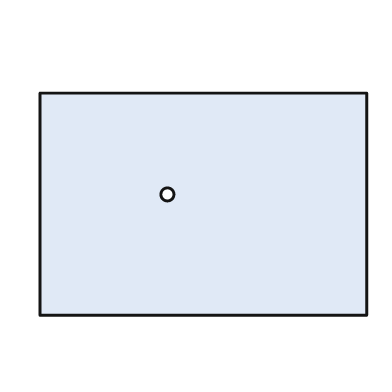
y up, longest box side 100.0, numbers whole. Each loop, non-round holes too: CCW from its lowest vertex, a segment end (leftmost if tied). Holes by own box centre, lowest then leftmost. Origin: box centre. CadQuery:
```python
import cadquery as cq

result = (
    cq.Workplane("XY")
    .moveTo(-50.0, -34.0)
    .lineTo(50.0, -34.0)
    .lineTo(50.0, 34.0)
    .lineTo(-50.0, 34.0)
    .close()
    .moveTo(-11.0, 3.0)
    .circle(2.0)
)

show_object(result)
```